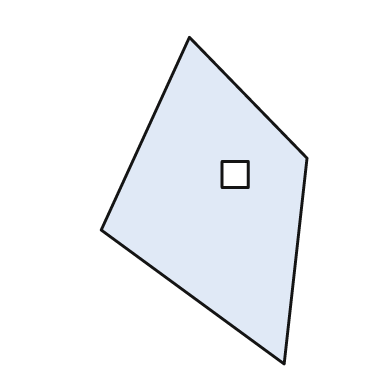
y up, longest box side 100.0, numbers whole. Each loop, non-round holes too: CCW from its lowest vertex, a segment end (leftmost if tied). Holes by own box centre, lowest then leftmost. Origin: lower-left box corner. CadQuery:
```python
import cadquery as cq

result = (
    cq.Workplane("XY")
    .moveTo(56.0, 0.0)
    .lineTo(63.0, 63.0)
    .lineTo(27.0, 100.0)
    .lineTo(0.0, 41.0)
    .close()
    .moveTo(37.0, 54.0)
    .lineTo(45.0, 54.0)
    .lineTo(45.0, 62.0)
    .lineTo(37.0, 62.0)
    .close()
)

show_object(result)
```